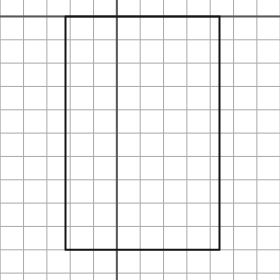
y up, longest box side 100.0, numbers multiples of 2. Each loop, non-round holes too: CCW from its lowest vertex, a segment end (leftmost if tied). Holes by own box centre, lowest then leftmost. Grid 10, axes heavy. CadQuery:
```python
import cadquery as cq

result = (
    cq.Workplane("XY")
    .moveTo(-22.0, -100.0)
    .lineTo(44.0, -100.0)
    .lineTo(44.0, 0.0)
    .lineTo(-22.0, 0.0)
    .close()
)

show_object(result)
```